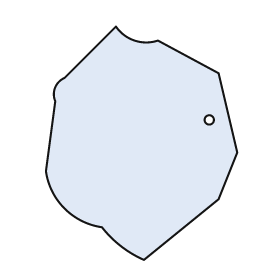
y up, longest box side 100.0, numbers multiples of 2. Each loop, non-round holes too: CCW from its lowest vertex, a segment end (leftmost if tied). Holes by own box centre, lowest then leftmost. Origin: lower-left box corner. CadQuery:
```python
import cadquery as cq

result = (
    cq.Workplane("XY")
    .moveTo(42.0, 0.0)
    .lineTo(74.0, 26.0)
    .lineTo(82.0, 46.0)
    .lineTo(74.0, 80.0)
    .lineTo(48.0, 94.0)
    .threePointArc((38.0, 94.0), (30.0, 100.0))
    .lineTo(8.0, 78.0)
    .threePointArc((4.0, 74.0), (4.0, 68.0))
    .lineTo(0.0, 38.0)
    .threePointArc((8.0, 22.0), (24.0, 14.0))
    .threePointArc((32.0, 6.0), (42.0, 0.0))
    .close()
    .moveTo(70.0, 60.0)
    .circle(2.0)
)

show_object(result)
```